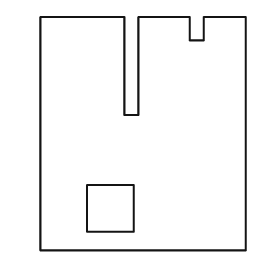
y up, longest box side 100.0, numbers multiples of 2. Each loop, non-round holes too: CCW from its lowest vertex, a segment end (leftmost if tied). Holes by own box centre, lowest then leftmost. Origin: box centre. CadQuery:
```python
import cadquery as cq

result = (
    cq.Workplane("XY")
    .moveTo(-44.0, -50.0)
    .lineTo(44.0, -50.0)
    .lineTo(44.0, 50.0)
    .lineTo(26.0, 50.0)
    .lineTo(26.0, 40.0)
    .lineTo(20.0, 40.0)
    .lineTo(20.0, 50.0)
    .lineTo(-2.0, 50.0)
    .lineTo(-2.0, 8.0)
    .lineTo(-8.0, 8.0)
    .lineTo(-8.0, 50.0)
    .lineTo(-44.0, 50.0)
    .close()
    .moveTo(-24.0, -42.0)
    .lineTo(-4.0, -42.0)
    .lineTo(-4.0, -22.0)
    .lineTo(-24.0, -22.0)
    .close()
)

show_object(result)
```